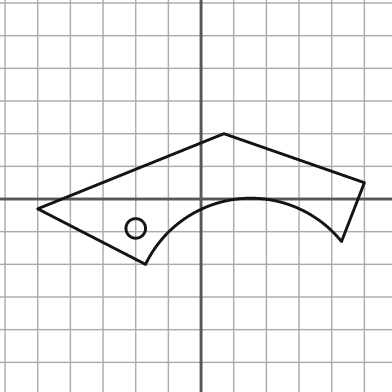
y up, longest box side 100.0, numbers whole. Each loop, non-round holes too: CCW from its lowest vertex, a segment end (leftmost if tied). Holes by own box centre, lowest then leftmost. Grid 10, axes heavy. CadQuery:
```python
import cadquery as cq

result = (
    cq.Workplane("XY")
    .moveTo(-17.0, -20.0)
    .threePointArc((11.0, 0.0), (43.0, -13.0))
    .lineTo(50.0, 5.0)
    .lineTo(7.0, 20.0)
    .lineTo(-50.0, -3.0)
    .close()
    .moveTo(-20.0, -9.0)
    .circle(3.0)
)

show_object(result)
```